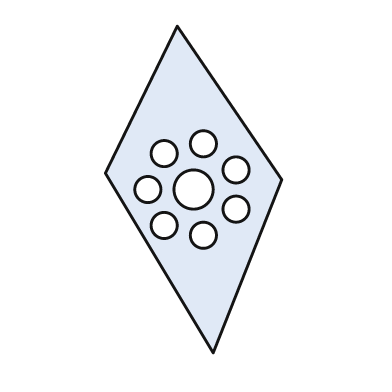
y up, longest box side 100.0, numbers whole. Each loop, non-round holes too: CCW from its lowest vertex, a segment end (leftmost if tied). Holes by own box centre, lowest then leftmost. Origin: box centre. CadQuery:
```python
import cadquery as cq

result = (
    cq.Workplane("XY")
    .moveTo(6.0, -50.0)
    .lineTo(27.0, 3.0)
    .lineTo(-5.0, 50.0)
    .lineTo(-27.0, 5.0)
    .close()
    .moveTo(3.0, -14.0)
    .circle(4.0)
    .moveTo(-9.0, -11.0)
    .circle(4.0)
    .moveTo(13.0, -6.0)
    .circle(4.0)
    .moveTo(-14.0, 0.0)
    .circle(4.0)
    .moveTo(0.0, 0.0)
    .circle(6.0)
    .moveTo(13.0, 6.0)
    .circle(4.0)
    .moveTo(-9.0, 11.0)
    .circle(4.0)
    .moveTo(3.0, 14.0)
    .circle(4.0)
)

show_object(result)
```